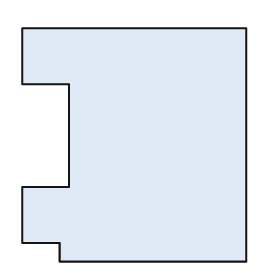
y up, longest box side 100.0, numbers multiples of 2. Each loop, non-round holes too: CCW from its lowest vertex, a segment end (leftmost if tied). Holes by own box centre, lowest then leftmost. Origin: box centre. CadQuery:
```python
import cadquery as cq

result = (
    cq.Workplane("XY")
    .moveTo(-32.0, -50.0)
    .lineTo(48.0, -50.0)
    .lineTo(48.0, 50.0)
    .lineTo(-48.0, 50.0)
    .lineTo(-48.0, 26.0)
    .lineTo(-28.0, 26.0)
    .lineTo(-28.0, -18.0)
    .lineTo(-48.0, -18.0)
    .lineTo(-48.0, -42.0)
    .lineTo(-32.0, -42.0)
    .close()
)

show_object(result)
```